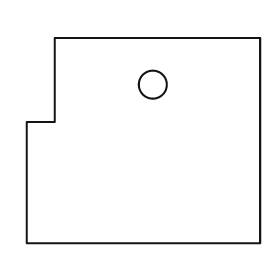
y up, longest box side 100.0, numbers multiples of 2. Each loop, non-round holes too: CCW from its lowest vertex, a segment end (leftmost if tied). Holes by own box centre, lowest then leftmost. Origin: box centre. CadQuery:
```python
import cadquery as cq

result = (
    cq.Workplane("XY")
    .moveTo(-50.0, -44.0)
    .lineTo(50.0, -44.0)
    .lineTo(50.0, 44.0)
    .lineTo(-38.0, 44.0)
    .lineTo(-38.0, 8.0)
    .lineTo(-50.0, 8.0)
    .close()
    .moveTo(4.0, 24.0)
    .circle(6.0)
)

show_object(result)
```